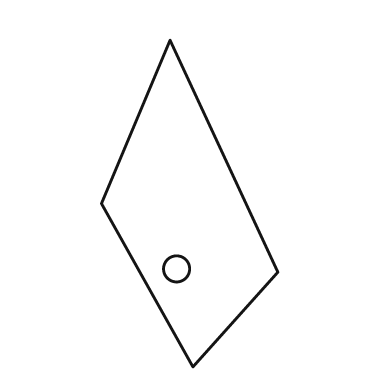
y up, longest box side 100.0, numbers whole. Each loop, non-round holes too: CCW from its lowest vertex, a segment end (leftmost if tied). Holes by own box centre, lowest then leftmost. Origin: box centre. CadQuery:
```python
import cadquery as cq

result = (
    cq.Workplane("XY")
    .moveTo(1.0, -50.0)
    .lineTo(27.0, -21.0)
    .lineTo(-6.0, 50.0)
    .lineTo(-27.0, 0.0)
    .close()
    .moveTo(-4.0, -20.0)
    .circle(4.0)
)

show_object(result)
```